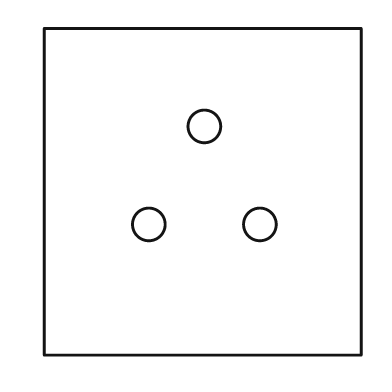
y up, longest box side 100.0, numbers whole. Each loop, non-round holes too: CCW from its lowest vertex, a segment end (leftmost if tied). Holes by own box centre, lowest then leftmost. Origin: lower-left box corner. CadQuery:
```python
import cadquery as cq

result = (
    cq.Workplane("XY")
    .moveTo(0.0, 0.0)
    .lineTo(97.0, 0.0)
    .lineTo(97.0, 100.0)
    .lineTo(0.0, 100.0)
    .close()
    .moveTo(32.0, 40.0)
    .circle(5.0)
    .moveTo(66.0, 40.0)
    .circle(5.0)
    .moveTo(49.0, 70.0)
    .circle(5.0)
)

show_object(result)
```